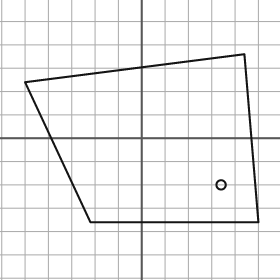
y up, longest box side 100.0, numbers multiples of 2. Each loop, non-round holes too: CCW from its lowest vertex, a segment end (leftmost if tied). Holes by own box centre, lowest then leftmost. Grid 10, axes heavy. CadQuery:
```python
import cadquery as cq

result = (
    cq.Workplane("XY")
    .moveTo(-22.0, -36.0)
    .lineTo(50.0, -36.0)
    .lineTo(44.0, 36.0)
    .lineTo(-50.0, 24.0)
    .close()
    .moveTo(34.0, -20.0)
    .circle(2.0)
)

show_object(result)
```